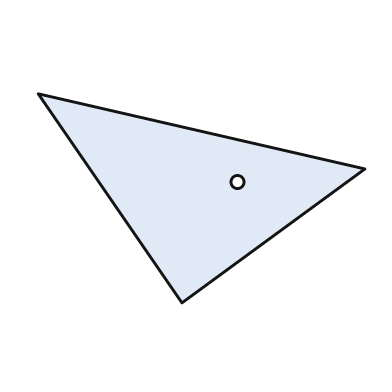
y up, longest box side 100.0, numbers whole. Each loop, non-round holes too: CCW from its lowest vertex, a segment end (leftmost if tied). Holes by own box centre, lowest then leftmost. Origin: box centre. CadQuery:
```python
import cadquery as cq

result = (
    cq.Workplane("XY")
    .moveTo(-6.0, -32.0)
    .lineTo(50.0, 9.0)
    .lineTo(-50.0, 32.0)
    .close()
    .moveTo(11.0, 5.0)
    .circle(2.0)
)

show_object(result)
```